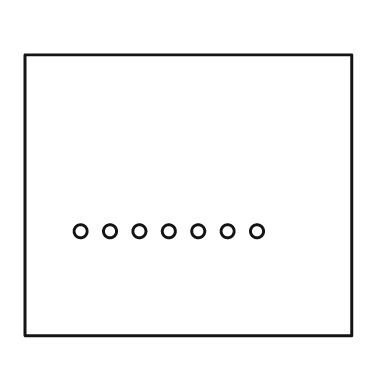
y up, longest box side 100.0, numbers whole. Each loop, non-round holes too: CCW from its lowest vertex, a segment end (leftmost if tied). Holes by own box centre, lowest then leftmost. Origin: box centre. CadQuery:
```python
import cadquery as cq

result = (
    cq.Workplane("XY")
    .moveTo(-50.0, -43.0)
    .lineTo(50.0, -43.0)
    .lineTo(50.0, 43.0)
    .lineTo(-50.0, 43.0)
    .close()
    .moveTo(-33.0, -11.0)
    .circle(2.0)
    .moveTo(-24.0, -11.0)
    .circle(2.0)
    .moveTo(-15.0, -11.0)
    .circle(2.0)
    .moveTo(-6.0, -11.0)
    .circle(2.0)
    .moveTo(3.0, -11.0)
    .circle(2.0)
    .moveTo(12.0, -11.0)
    .circle(2.0)
    .moveTo(21.0, -11.0)
    .circle(2.0)
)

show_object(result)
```